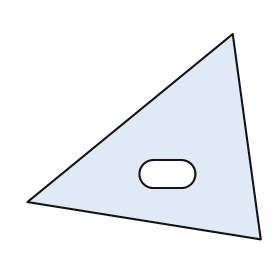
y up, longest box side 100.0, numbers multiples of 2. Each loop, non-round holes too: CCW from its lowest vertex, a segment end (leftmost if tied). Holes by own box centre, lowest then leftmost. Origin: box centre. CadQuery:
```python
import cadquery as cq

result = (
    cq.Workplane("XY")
    .moveTo(50.0, -44.0)
    .lineTo(38.0, 44.0)
    .lineTo(-50.0, -28.0)
    .close()
    .moveTo(4.0, -22.0)
    .lineTo(16.0, -22.0)
    .threePointArc((22.0, -16.0), (16.0, -10.0))
    .lineTo(4.0, -10.0)
    .threePointArc((-2.0, -16.0), (4.0, -22.0))
    .close()
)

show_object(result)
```